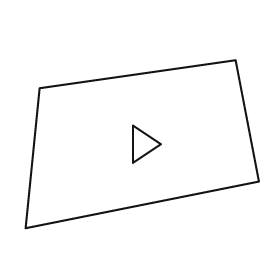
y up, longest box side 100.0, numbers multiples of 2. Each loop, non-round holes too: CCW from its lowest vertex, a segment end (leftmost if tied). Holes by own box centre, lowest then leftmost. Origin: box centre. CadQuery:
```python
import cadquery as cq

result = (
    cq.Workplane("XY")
    .moveTo(-50.0, -36.0)
    .lineTo(50.0, -16.0)
    .lineTo(40.0, 36.0)
    .lineTo(-44.0, 24.0)
    .close()
    .moveTo(-4.0, -8.0)
    .lineTo(8.0, 0.0)
    .lineTo(-4.0, 8.0)
    .close()
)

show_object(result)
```